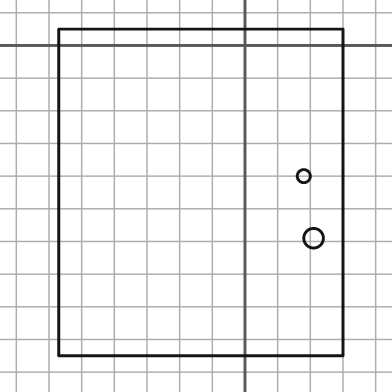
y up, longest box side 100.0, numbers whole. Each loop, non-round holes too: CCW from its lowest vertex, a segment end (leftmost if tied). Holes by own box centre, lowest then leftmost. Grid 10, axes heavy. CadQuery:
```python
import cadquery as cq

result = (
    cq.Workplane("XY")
    .moveTo(-57.0, -95.0)
    .lineTo(30.0, -95.0)
    .lineTo(30.0, 5.0)
    .lineTo(-57.0, 5.0)
    .close()
    .moveTo(21.0, -59.0)
    .circle(3.0)
    .moveTo(18.0, -40.0)
    .circle(2.0)
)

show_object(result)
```